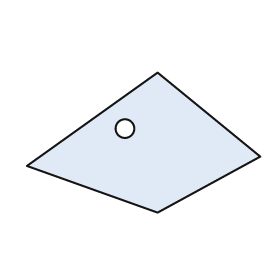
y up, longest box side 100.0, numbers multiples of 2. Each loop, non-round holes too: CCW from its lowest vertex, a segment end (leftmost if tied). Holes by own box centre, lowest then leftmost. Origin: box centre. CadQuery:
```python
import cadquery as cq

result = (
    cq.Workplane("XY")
    .moveTo(6.0, -30.0)
    .lineTo(50.0, -6.0)
    .lineTo(6.0, 30.0)
    .lineTo(-50.0, -10.0)
    .close()
    .moveTo(-8.0, 6.0)
    .circle(4.0)
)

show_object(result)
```